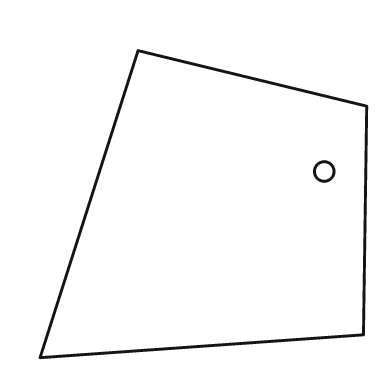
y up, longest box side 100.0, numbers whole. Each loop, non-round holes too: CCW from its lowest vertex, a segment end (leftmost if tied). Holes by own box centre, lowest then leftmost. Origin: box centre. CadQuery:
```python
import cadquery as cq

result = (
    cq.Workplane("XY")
    .moveTo(-50.0, -47.0)
    .lineTo(49.0, -40.0)
    .lineTo(50.0, 30.0)
    .lineTo(-20.0, 47.0)
    .close()
    .moveTo(37.0, 10.0)
    .circle(3.0)
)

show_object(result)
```